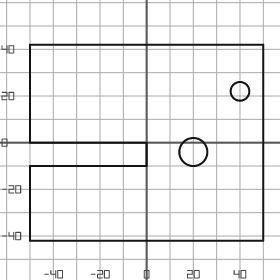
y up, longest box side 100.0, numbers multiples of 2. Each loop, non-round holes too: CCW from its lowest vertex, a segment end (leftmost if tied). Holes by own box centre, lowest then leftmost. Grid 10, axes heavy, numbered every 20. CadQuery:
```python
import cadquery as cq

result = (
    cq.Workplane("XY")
    .moveTo(-50.0, -42.0)
    .lineTo(50.0, -42.0)
    .lineTo(50.0, 42.0)
    .lineTo(-50.0, 42.0)
    .lineTo(-50.0, 0.0)
    .lineTo(0.0, 0.0)
    .lineTo(0.0, -10.0)
    .lineTo(-50.0, -10.0)
    .close()
    .moveTo(20.0, -4.0)
    .circle(6.0)
    .moveTo(40.0, 22.0)
    .circle(4.0)
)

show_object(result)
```